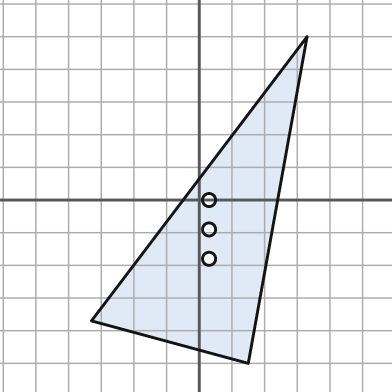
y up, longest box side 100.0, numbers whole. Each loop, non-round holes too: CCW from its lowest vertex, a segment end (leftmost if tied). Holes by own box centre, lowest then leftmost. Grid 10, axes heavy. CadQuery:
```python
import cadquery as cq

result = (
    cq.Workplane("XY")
    .moveTo(15.0, -50.0)
    .lineTo(33.0, 50.0)
    .lineTo(-33.0, -37.0)
    .close()
    .moveTo(3.0, -18.0)
    .circle(2.0)
    .moveTo(3.0, -9.0)
    .circle(2.0)
    .moveTo(3.0, 0.0)
    .circle(2.0)
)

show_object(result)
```